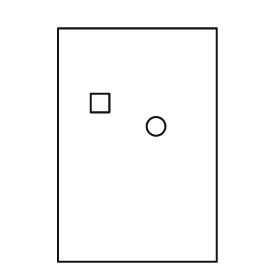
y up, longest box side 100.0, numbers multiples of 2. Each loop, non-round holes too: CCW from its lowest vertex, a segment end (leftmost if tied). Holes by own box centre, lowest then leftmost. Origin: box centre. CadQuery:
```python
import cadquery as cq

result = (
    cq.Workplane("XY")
    .moveTo(-34.0, -50.0)
    .lineTo(34.0, -50.0)
    .lineTo(34.0, 50.0)
    .lineTo(-34.0, 50.0)
    .close()
    .moveTo(8.0, 8.0)
    .circle(4.0)
    .moveTo(-20.0, 14.0)
    .lineTo(-12.0, 14.0)
    .lineTo(-12.0, 22.0)
    .lineTo(-20.0, 22.0)
    .close()
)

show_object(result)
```